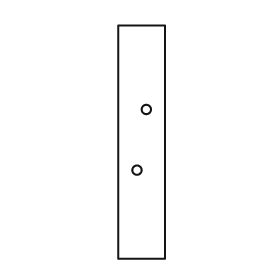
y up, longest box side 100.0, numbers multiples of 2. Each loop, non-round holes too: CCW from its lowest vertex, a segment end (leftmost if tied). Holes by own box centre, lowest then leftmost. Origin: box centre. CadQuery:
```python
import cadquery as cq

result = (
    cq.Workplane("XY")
    .moveTo(-10.0, -50.0)
    .lineTo(10.0, -50.0)
    .lineTo(10.0, 50.0)
    .lineTo(-10.0, 50.0)
    .close()
    .moveTo(-2.0, -12.0)
    .circle(2.0)
    .moveTo(2.0, 14.0)
    .circle(2.0)
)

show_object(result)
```